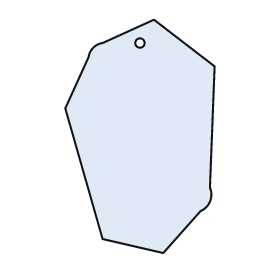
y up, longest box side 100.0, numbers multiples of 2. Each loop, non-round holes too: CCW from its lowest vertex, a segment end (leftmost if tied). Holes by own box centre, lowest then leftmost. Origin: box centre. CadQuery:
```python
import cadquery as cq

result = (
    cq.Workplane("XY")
    .moveTo(10.0, -50.0)
    .lineTo(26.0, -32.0)
    .threePointArc((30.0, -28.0), (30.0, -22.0))
    .lineTo(32.0, 30.0)
    .lineTo(6.0, 50.0)
    .lineTo(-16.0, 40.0)
    .threePointArc((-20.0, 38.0), (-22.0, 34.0))
    .lineTo(-32.0, 12.0)
    .lineTo(-16.0, -44.0)
    .close()
    .moveTo(0.0, 40.0)
    .circle(2.0)
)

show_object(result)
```